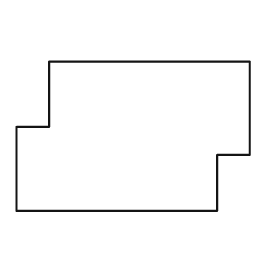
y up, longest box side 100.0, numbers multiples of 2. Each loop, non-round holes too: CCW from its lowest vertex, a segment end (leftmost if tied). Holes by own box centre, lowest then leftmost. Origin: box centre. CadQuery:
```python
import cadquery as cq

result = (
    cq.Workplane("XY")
    .moveTo(-50.0, -32.0)
    .lineTo(36.0, -32.0)
    .lineTo(36.0, -8.0)
    .lineTo(50.0, -8.0)
    .lineTo(50.0, 32.0)
    .lineTo(-36.0, 32.0)
    .lineTo(-36.0, 4.0)
    .lineTo(-50.0, 4.0)
    .close()
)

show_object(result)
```